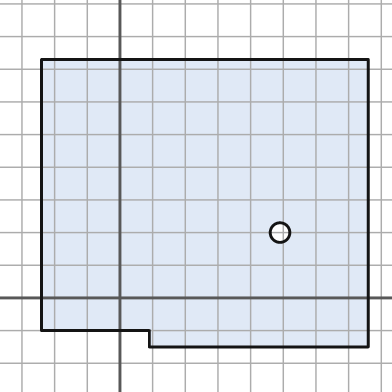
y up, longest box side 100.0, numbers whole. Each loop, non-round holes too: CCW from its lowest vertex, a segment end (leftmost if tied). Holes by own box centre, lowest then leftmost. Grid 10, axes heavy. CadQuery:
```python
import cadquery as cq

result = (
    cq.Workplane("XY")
    .moveTo(9.0, -15.0)
    .lineTo(76.0, -15.0)
    .lineTo(76.0, 73.0)
    .lineTo(-24.0, 73.0)
    .lineTo(-24.0, -10.0)
    .lineTo(9.0, -10.0)
    .close()
    .moveTo(49.0, 20.0)
    .circle(3.0)
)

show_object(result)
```